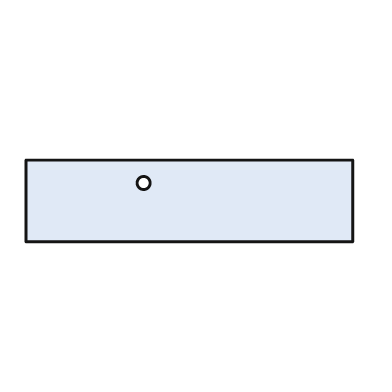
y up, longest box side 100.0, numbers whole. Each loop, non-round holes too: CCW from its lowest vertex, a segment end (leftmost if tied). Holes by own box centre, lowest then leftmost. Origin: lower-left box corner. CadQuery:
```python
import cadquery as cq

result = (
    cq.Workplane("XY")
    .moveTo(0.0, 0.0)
    .lineTo(100.0, 0.0)
    .lineTo(100.0, 25.0)
    .lineTo(0.0, 25.0)
    .close()
    .moveTo(36.0, 18.0)
    .circle(2.0)
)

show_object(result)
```